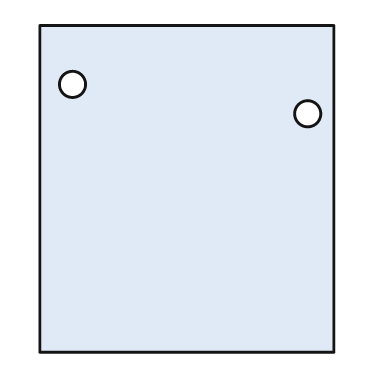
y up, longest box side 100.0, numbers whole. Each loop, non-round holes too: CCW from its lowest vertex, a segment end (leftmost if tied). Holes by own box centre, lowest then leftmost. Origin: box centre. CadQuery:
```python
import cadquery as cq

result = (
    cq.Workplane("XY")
    .moveTo(-45.0, -50.0)
    .lineTo(45.0, -50.0)
    .lineTo(45.0, 50.0)
    .lineTo(-45.0, 50.0)
    .close()
    .moveTo(37.0, 23.0)
    .circle(4.0)
    .moveTo(-35.0, 32.0)
    .circle(4.0)
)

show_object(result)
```